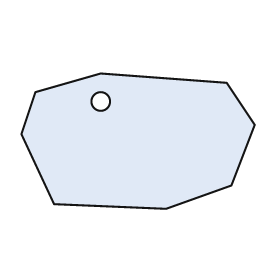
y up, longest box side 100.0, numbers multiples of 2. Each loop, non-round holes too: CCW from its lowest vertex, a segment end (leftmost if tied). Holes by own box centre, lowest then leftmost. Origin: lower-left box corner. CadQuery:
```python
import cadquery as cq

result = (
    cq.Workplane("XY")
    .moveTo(62.0, 0.0)
    .lineTo(90.0, 10.0)
    .lineTo(100.0, 36.0)
    .lineTo(88.0, 54.0)
    .lineTo(34.0, 58.0)
    .lineTo(6.0, 50.0)
    .lineTo(0.0, 32.0)
    .lineTo(14.0, 2.0)
    .close()
    .moveTo(34.0, 46.0)
    .circle(4.0)
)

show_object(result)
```